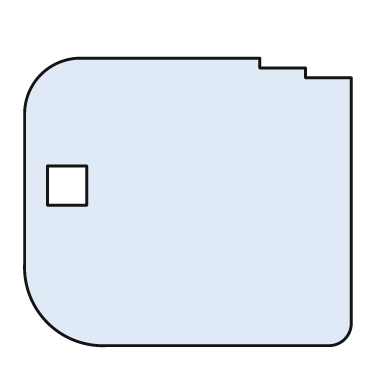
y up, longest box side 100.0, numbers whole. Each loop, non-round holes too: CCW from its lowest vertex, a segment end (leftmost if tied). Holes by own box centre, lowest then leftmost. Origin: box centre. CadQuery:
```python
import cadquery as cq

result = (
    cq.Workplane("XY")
    .moveTo(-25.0, -44.0)
    .lineTo(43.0, -44.0)
    .threePointArc((48.0, -42.0), (50.0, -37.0))
    .lineTo(50.0, 38.0)
    .lineTo(36.0, 38.0)
    .lineTo(36.0, 41.0)
    .lineTo(22.0, 41.0)
    .lineTo(22.0, 44.0)
    .lineTo(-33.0, 44.0)
    .threePointArc((-45.0, 39.0), (-50.0, 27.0))
    .lineTo(-50.0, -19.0)
    .threePointArc((-43.0, -37.0), (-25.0, -44.0))
    .close()
    .moveTo(-43.0, -1.0)
    .lineTo(-31.0, -1.0)
    .lineTo(-31.0, 11.0)
    .lineTo(-43.0, 11.0)
    .close()
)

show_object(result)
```